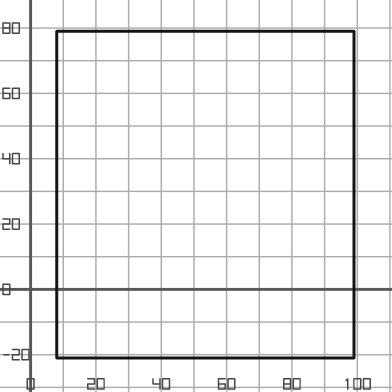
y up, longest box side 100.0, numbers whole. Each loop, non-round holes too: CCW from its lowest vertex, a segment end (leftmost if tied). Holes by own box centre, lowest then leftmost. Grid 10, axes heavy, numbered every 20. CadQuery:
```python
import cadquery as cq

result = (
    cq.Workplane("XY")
    .moveTo(8.0, -21.0)
    .lineTo(99.0, -21.0)
    .lineTo(99.0, 79.0)
    .lineTo(8.0, 79.0)
    .close()
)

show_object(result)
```